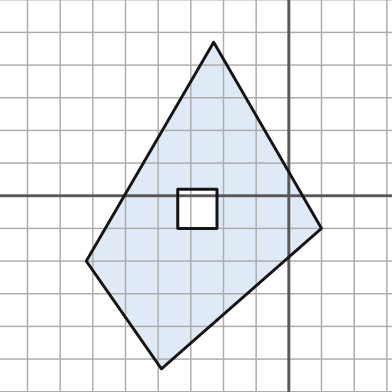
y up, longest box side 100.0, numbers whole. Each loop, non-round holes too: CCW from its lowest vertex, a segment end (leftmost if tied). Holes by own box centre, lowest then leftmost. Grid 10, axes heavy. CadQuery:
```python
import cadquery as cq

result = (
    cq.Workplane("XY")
    .moveTo(-39.0, -53.0)
    .lineTo(10.0, -10.0)
    .lineTo(-23.0, 47.0)
    .lineTo(-62.0, -20.0)
    .close()
    .moveTo(-34.0, -10.0)
    .lineTo(-22.0, -10.0)
    .lineTo(-22.0, 2.0)
    .lineTo(-34.0, 2.0)
    .close()
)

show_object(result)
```